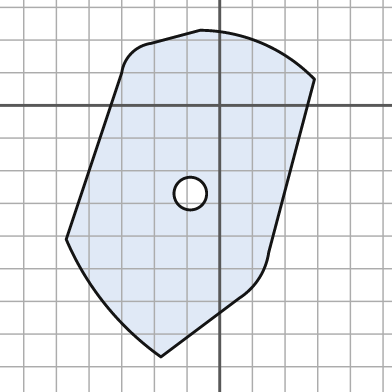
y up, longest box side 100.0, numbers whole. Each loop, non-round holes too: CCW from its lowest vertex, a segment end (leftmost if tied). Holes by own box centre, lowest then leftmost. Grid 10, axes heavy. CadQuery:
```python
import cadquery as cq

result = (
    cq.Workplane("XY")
    .moveTo(-18.0, -77.0)
    .lineTo(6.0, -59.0)
    .threePointArc((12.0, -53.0), (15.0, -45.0))
    .lineTo(29.0, 8.0)
    .threePointArc((13.0, 19.0), (-6.0, 23.0))
    .lineTo(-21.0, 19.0)
    .threePointArc((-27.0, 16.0), (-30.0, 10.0))
    .lineTo(-47.0, -41.0)
    .threePointArc((-35.0, -61.0), (-18.0, -77.0))
    .close()
    .moveTo(-9.0, -27.0)
    .circle(5.0)
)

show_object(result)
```